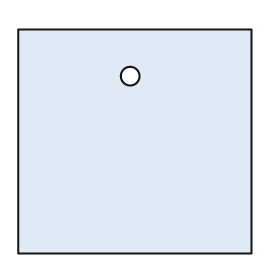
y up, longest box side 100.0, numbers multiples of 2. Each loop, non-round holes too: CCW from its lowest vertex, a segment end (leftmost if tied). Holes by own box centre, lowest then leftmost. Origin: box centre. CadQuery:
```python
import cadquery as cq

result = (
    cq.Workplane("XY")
    .moveTo(-50.0, -48.0)
    .lineTo(50.0, -48.0)
    .lineTo(50.0, 48.0)
    .lineTo(-50.0, 48.0)
    .close()
    .moveTo(-2.0, 28.0)
    .circle(4.0)
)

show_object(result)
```